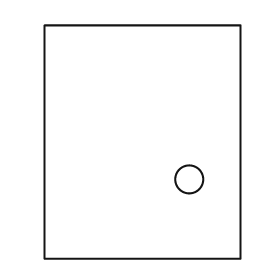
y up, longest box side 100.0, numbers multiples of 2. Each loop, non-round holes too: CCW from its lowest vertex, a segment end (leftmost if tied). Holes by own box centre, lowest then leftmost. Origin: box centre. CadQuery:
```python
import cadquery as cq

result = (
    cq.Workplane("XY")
    .moveTo(-42.0, -50.0)
    .lineTo(42.0, -50.0)
    .lineTo(42.0, 50.0)
    .lineTo(-42.0, 50.0)
    .close()
    .moveTo(20.0, -16.0)
    .circle(6.0)
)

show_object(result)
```